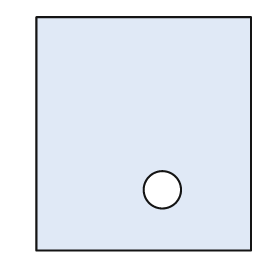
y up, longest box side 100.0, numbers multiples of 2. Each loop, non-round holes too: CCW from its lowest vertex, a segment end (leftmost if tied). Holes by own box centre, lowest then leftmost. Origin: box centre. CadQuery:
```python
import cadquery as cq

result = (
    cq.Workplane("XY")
    .moveTo(-46.0, -50.0)
    .lineTo(46.0, -50.0)
    .lineTo(46.0, 50.0)
    .lineTo(-46.0, 50.0)
    .close()
    .moveTo(8.0, -24.0)
    .circle(8.0)
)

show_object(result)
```